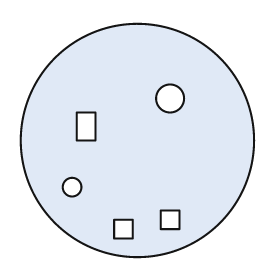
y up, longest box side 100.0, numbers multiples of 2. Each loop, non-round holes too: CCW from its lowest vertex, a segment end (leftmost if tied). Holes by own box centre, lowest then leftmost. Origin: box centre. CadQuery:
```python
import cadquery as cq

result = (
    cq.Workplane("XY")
    .moveTo(0.0, 0.0)
    .circle(50.0)
    .moveTo(-10.0, -42.0)
    .lineTo(-2.0, -42.0)
    .lineTo(-2.0, -34.0)
    .lineTo(-10.0, -34.0)
    .close()
    .moveTo(10.0, -38.0)
    .lineTo(18.0, -38.0)
    .lineTo(18.0, -30.0)
    .lineTo(10.0, -30.0)
    .close()
    .moveTo(-28.0, -20.0)
    .circle(4.0)
    .moveTo(-26.0, 0.0)
    .lineTo(-18.0, 0.0)
    .lineTo(-18.0, 12.0)
    .lineTo(-26.0, 12.0)
    .close()
    .moveTo(14.0, 18.0)
    .circle(6.0)
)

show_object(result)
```